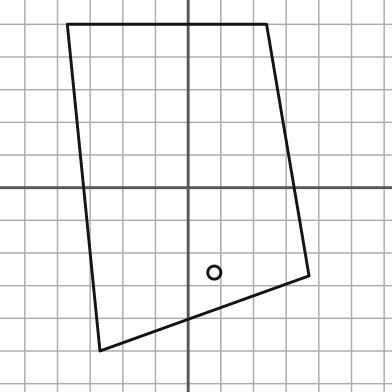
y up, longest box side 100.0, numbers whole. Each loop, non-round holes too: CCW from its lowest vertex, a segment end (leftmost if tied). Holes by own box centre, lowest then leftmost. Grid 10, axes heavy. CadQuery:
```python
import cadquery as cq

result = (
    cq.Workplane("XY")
    .moveTo(-27.0, -50.0)
    .lineTo(37.0, -27.0)
    .lineTo(24.0, 50.0)
    .lineTo(-37.0, 50.0)
    .close()
    .moveTo(8.0, -26.0)
    .circle(2.0)
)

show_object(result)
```